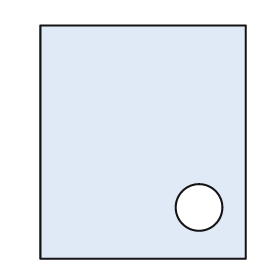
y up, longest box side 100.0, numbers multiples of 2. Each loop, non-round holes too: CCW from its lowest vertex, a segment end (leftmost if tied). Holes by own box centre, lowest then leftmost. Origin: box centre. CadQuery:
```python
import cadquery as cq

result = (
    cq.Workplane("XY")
    .moveTo(-44.0, -50.0)
    .lineTo(44.0, -50.0)
    .lineTo(44.0, 50.0)
    .lineTo(-44.0, 50.0)
    .close()
    .moveTo(24.0, -28.0)
    .circle(10.0)
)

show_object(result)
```